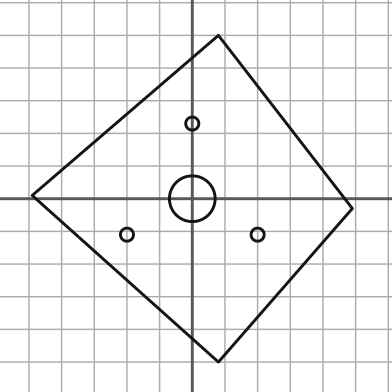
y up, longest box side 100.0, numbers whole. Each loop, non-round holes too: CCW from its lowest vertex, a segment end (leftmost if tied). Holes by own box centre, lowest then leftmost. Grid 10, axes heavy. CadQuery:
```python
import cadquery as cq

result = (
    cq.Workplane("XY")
    .moveTo(8.0, -50.0)
    .lineTo(49.0, -3.0)
    .lineTo(8.0, 50.0)
    .lineTo(-49.0, 1.0)
    .close()
    .moveTo(-20.0, -11.0)
    .circle(2.0)
    .moveTo(20.0, -11.0)
    .circle(2.0)
    .moveTo(0.0, 0.0)
    .circle(7.0)
    .moveTo(0.0, 23.0)
    .circle(2.0)
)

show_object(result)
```